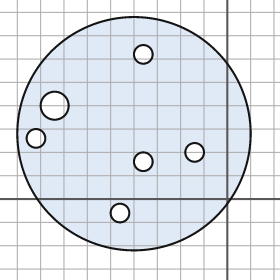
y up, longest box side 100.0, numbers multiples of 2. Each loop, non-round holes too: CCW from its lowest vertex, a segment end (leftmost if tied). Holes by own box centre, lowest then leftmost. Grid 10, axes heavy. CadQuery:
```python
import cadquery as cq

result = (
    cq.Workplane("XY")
    .moveTo(-40.0, 28.0)
    .circle(50.0)
    .moveTo(-46.0, -6.0)
    .circle(4.0)
    .moveTo(-36.0, 16.0)
    .circle(4.0)
    .moveTo(-14.0, 20.0)
    .circle(4.0)
    .moveTo(-82.0, 26.0)
    .circle(4.0)
    .moveTo(-74.0, 40.0)
    .circle(6.0)
    .moveTo(-36.0, 62.0)
    .circle(4.0)
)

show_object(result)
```